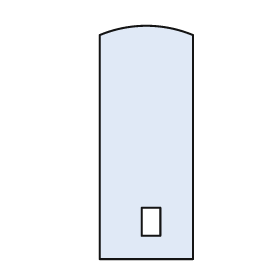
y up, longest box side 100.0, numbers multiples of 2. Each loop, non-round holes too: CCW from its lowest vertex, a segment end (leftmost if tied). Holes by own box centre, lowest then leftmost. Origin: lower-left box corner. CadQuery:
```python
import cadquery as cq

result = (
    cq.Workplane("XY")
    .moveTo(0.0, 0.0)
    .lineTo(40.0, 0.0)
    .lineTo(40.0, 96.0)
    .threePointArc((20.0, 100.0), (0.0, 96.0))
    .close()
    .moveTo(18.0, 10.0)
    .lineTo(26.0, 10.0)
    .lineTo(26.0, 22.0)
    .lineTo(18.0, 22.0)
    .close()
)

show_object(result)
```